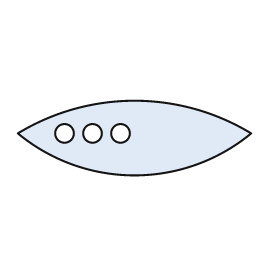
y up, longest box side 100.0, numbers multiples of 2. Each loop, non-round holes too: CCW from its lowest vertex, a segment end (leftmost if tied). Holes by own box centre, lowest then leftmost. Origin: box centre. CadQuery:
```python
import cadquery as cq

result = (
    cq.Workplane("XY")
    .moveTo(-50.0, 2.0)
    .threePointArc((0.0, -16.0), (50.0, 2.0))
    .threePointArc((0.0, 16.0), (-50.0, 2.0))
    .close()
    .moveTo(-30.0, 2.0)
    .circle(4.0)
    .moveTo(-18.0, 2.0)
    .circle(4.0)
    .moveTo(-6.0, 2.0)
    .circle(4.0)
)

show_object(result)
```